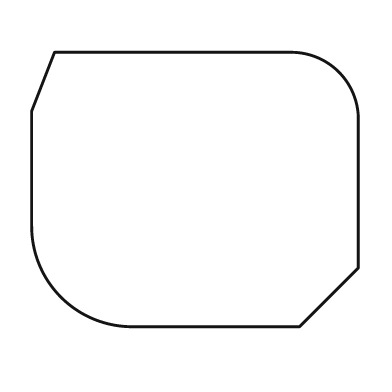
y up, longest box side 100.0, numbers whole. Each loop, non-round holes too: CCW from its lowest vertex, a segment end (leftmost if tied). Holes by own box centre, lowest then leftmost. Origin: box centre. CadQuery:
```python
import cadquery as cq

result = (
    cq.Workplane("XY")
    .moveTo(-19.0, -42.0)
    .lineTo(32.0, -42.0)
    .lineTo(50.0, -24.0)
    .lineTo(50.0, 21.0)
    .threePointArc((44.0, 36.0), (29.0, 42.0))
    .lineTo(-43.0, 42.0)
    .lineTo(-50.0, 24.0)
    .lineTo(-50.0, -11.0)
    .threePointArc((-41.0, -33.0), (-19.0, -42.0))
    .close()
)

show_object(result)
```